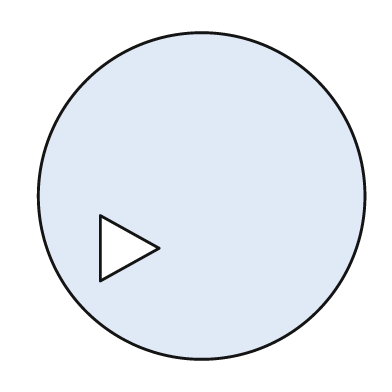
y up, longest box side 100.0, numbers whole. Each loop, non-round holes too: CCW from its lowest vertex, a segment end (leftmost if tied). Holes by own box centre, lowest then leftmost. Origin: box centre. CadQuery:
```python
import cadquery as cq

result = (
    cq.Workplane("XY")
    .moveTo(0.0, 0.0)
    .circle(50.0)
    .moveTo(-31.0, -26.0)
    .lineTo(-13.0, -16.0)
    .lineTo(-31.0, -6.0)
    .close()
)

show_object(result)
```